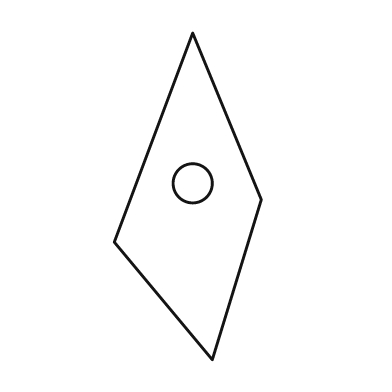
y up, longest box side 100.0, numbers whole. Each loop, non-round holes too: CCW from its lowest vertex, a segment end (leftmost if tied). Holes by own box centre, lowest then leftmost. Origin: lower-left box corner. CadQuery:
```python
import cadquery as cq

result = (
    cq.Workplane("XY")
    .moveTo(30.0, 0.0)
    .lineTo(45.0, 49.0)
    .lineTo(24.0, 100.0)
    .lineTo(0.0, 36.0)
    .close()
    .moveTo(24.0, 54.0)
    .circle(6.0)
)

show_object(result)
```